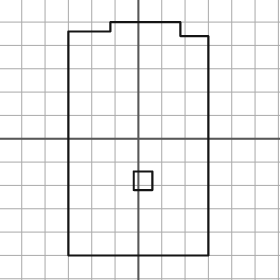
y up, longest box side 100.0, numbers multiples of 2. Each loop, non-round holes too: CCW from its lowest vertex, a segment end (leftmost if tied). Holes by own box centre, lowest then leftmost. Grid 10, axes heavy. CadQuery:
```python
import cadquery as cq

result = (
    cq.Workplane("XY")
    .moveTo(-30.0, -50.0)
    .lineTo(30.0, -50.0)
    .lineTo(30.0, 44.0)
    .lineTo(18.0, 44.0)
    .lineTo(18.0, 50.0)
    .lineTo(-12.0, 50.0)
    .lineTo(-12.0, 46.0)
    .lineTo(-30.0, 46.0)
    .close()
    .moveTo(-2.0, -22.0)
    .lineTo(6.0, -22.0)
    .lineTo(6.0, -14.0)
    .lineTo(-2.0, -14.0)
    .close()
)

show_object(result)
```